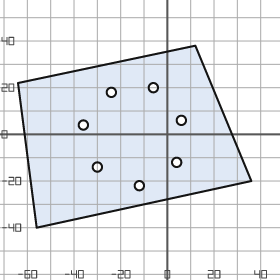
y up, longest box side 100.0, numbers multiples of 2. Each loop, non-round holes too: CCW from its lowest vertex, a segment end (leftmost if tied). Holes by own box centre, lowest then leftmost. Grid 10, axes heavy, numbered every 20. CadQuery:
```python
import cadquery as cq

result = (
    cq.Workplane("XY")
    .moveTo(-56.0, -40.0)
    .lineTo(36.0, -20.0)
    .lineTo(12.0, 38.0)
    .lineTo(-64.0, 22.0)
    .close()
    .moveTo(-12.0, -22.0)
    .circle(2.0)
    .moveTo(-30.0, -14.0)
    .circle(2.0)
    .moveTo(4.0, -12.0)
    .circle(2.0)
    .moveTo(-36.0, 4.0)
    .circle(2.0)
    .moveTo(6.0, 6.0)
    .circle(2.0)
    .moveTo(-24.0, 18.0)
    .circle(2.0)
    .moveTo(-6.0, 20.0)
    .circle(2.0)
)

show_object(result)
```